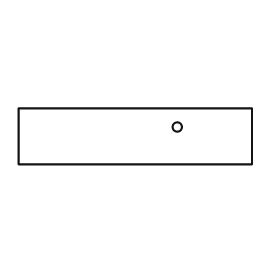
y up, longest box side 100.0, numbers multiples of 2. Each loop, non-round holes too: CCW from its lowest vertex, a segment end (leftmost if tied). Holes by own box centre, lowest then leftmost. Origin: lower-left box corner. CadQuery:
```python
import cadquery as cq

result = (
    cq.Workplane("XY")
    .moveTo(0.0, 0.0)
    .lineTo(100.0, 0.0)
    .lineTo(100.0, 24.0)
    .lineTo(0.0, 24.0)
    .close()
    .moveTo(68.0, 16.0)
    .circle(2.0)
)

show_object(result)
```